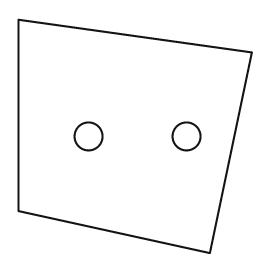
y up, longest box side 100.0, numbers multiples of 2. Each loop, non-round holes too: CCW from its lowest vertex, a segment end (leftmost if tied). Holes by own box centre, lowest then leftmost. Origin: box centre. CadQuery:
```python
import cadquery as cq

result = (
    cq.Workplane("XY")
    .moveTo(32.0, -50.0)
    .lineTo(50.0, 36.0)
    .lineTo(-50.0, 50.0)
    .lineTo(-50.0, -32.0)
    .close()
    .moveTo(-20.0, 0.0)
    .circle(6.0)
    .moveTo(22.0, 0.0)
    .circle(6.0)
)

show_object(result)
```